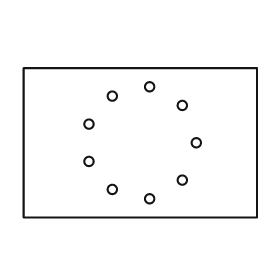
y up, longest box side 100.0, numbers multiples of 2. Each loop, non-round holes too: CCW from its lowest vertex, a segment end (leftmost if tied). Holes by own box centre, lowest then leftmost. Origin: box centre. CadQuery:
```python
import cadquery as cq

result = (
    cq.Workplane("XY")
    .moveTo(-50.0, -32.0)
    .lineTo(50.0, -32.0)
    .lineTo(50.0, 32.0)
    .lineTo(-50.0, 32.0)
    .close()
    .moveTo(4.0, -24.0)
    .circle(2.0)
    .moveTo(-12.0, -20.0)
    .circle(2.0)
    .moveTo(18.0, -16.0)
    .circle(2.0)
    .moveTo(-22.0, -8.0)
    .circle(2.0)
    .moveTo(24.0, 0.0)
    .circle(2.0)
    .moveTo(-22.0, 8.0)
    .circle(2.0)
    .moveTo(18.0, 16.0)
    .circle(2.0)
    .moveTo(-12.0, 20.0)
    .circle(2.0)
    .moveTo(4.0, 24.0)
    .circle(2.0)
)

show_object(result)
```